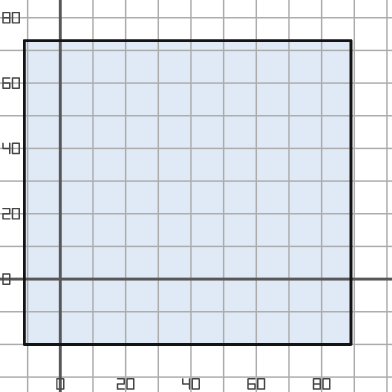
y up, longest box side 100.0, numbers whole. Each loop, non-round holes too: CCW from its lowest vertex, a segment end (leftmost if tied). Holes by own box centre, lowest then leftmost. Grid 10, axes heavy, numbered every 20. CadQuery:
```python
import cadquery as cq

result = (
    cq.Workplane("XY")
    .moveTo(-11.0, -20.0)
    .lineTo(89.0, -20.0)
    .lineTo(89.0, 73.0)
    .lineTo(-11.0, 73.0)
    .close()
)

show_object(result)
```